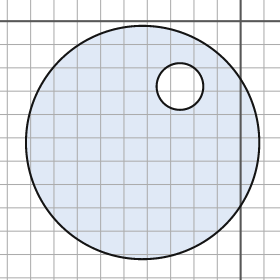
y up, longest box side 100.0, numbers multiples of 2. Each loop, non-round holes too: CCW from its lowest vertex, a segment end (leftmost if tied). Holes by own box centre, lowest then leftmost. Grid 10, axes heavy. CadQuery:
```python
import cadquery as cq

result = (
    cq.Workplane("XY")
    .moveTo(-42.0, -52.0)
    .circle(50.0)
    .moveTo(-26.0, -28.0)
    .circle(10.0)
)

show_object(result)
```